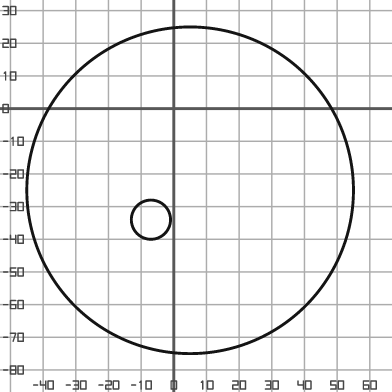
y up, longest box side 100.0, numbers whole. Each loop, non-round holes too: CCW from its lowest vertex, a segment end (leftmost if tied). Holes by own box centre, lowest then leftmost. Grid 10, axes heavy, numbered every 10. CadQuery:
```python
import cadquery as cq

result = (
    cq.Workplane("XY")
    .moveTo(5.0, -25.0)
    .circle(50.0)
    .moveTo(-7.0, -34.0)
    .circle(6.0)
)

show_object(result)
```